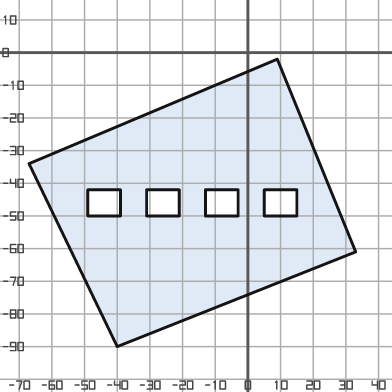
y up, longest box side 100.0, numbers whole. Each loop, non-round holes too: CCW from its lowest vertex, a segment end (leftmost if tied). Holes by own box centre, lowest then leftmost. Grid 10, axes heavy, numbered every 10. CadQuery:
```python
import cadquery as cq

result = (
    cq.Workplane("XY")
    .moveTo(-40.0, -90.0)
    .lineTo(33.0, -61.0)
    .lineTo(9.0, -2.0)
    .lineTo(-67.0, -34.0)
    .close()
    .moveTo(-49.0, -50.0)
    .lineTo(-39.0, -50.0)
    .lineTo(-39.0, -42.0)
    .lineTo(-49.0, -42.0)
    .close()
    .moveTo(-31.0, -50.0)
    .lineTo(-21.0, -50.0)
    .lineTo(-21.0, -42.0)
    .lineTo(-31.0, -42.0)
    .close()
    .moveTo(-13.0, -50.0)
    .lineTo(-3.0, -50.0)
    .lineTo(-3.0, -42.0)
    .lineTo(-13.0, -42.0)
    .close()
    .moveTo(5.0, -50.0)
    .lineTo(15.0, -50.0)
    .lineTo(15.0, -42.0)
    .lineTo(5.0, -42.0)
    .close()
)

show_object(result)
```